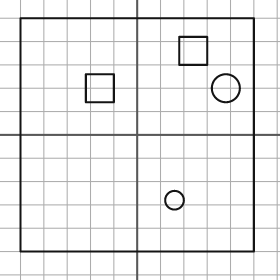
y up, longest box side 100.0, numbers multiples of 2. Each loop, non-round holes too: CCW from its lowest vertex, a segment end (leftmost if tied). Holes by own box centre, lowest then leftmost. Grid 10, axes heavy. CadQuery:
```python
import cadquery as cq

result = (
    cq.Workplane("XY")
    .moveTo(-50.0, -50.0)
    .lineTo(50.0, -50.0)
    .lineTo(50.0, 50.0)
    .lineTo(-50.0, 50.0)
    .close()
    .moveTo(16.0, -28.0)
    .circle(4.0)
    .moveTo(-22.0, 14.0)
    .lineTo(-10.0, 14.0)
    .lineTo(-10.0, 26.0)
    .lineTo(-22.0, 26.0)
    .close()
    .moveTo(38.0, 20.0)
    .circle(6.0)
    .moveTo(18.0, 30.0)
    .lineTo(30.0, 30.0)
    .lineTo(30.0, 42.0)
    .lineTo(18.0, 42.0)
    .close()
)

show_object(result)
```